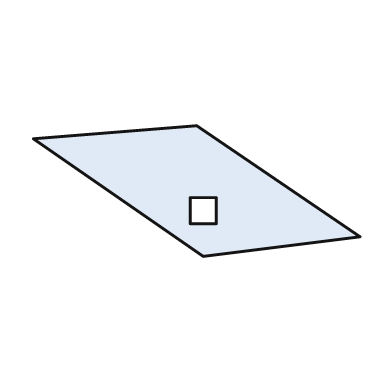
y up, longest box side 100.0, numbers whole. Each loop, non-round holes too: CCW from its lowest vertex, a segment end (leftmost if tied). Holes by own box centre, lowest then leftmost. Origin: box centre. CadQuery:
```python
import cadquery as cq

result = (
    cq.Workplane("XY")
    .moveTo(2.0, -20.0)
    .lineTo(50.0, -14.0)
    .lineTo(0.0, 20.0)
    .lineTo(-50.0, 16.0)
    .close()
    .moveTo(-2.0, -10.0)
    .lineTo(6.0, -10.0)
    .lineTo(6.0, -2.0)
    .lineTo(-2.0, -2.0)
    .close()
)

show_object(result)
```